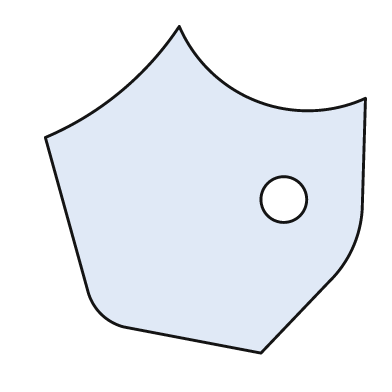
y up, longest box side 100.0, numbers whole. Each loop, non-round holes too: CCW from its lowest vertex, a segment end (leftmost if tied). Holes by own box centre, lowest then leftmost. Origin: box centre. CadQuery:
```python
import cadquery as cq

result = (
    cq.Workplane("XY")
    .moveTo(17.0, -50.0)
    .lineTo(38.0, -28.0)
    .threePointArc((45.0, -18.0), (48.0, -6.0))
    .lineTo(49.0, 28.0)
    .threePointArc((16.0, 27.0), (-8.0, 50.0))
    .threePointArc((-26.0, 30.0), (-49.0, 16.0))
    .lineTo(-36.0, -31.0)
    .threePointArc((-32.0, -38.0), (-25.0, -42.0))
    .close()
    .moveTo(24.0, -3.0)
    .circle(7.0)
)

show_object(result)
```